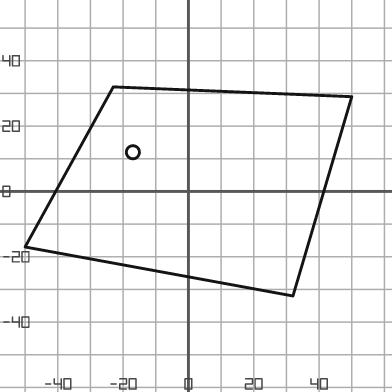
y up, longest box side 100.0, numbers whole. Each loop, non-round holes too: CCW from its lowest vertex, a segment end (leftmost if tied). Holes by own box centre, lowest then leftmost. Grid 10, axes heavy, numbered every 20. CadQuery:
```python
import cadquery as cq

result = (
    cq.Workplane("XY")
    .moveTo(32.0, -32.0)
    .lineTo(50.0, 29.0)
    .lineTo(-23.0, 32.0)
    .lineTo(-50.0, -17.0)
    .close()
    .moveTo(-17.0, 12.0)
    .circle(2.0)
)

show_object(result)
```